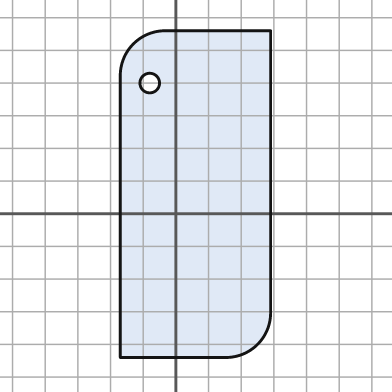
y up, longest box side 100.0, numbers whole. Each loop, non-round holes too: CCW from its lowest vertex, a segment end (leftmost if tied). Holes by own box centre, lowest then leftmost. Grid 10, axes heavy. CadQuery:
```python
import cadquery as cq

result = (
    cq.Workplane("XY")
    .moveTo(-17.0, -44.0)
    .lineTo(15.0, -44.0)
    .threePointArc((25.0, -40.0), (29.0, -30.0))
    .lineTo(29.0, 56.0)
    .lineTo(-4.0, 56.0)
    .threePointArc((-13.0, 52.0), (-17.0, 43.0))
    .close()
    .moveTo(-8.0, 40.0)
    .circle(3.0)
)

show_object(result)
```